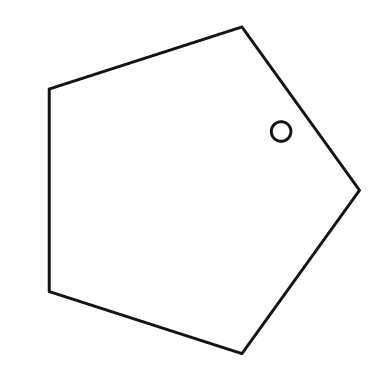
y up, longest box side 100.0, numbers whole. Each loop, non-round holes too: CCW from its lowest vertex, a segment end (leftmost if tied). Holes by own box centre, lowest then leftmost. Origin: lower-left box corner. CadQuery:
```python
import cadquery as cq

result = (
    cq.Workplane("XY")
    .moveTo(59.0, 0.0)
    .lineTo(95.0, 50.0)
    .lineTo(59.0, 100.0)
    .lineTo(0.0, 81.0)
    .lineTo(0.0, 19.0)
    .close()
    .moveTo(71.0, 68.0)
    .circle(3.0)
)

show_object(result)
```